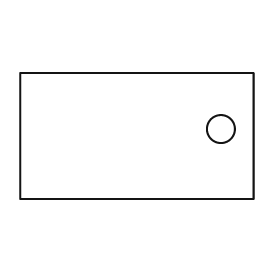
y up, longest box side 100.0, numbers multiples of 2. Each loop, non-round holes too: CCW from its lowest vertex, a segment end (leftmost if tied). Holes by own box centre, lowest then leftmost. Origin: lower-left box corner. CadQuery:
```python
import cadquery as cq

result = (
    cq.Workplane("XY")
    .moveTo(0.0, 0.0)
    .lineTo(100.0, 0.0)
    .lineTo(100.0, 54.0)
    .lineTo(0.0, 54.0)
    .close()
    .moveTo(86.0, 30.0)
    .circle(6.0)
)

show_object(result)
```